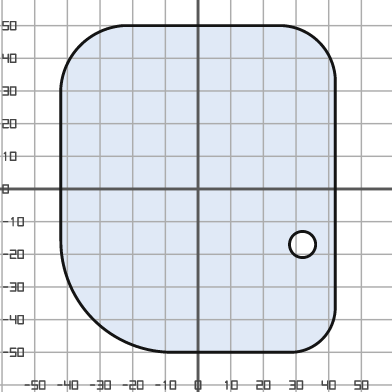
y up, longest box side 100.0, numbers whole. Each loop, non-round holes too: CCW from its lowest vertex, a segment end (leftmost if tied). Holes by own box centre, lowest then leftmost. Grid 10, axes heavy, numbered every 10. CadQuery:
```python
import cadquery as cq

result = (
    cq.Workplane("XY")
    .moveTo(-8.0, -50.0)
    .lineTo(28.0, -50.0)
    .threePointArc((38.0, -46.0), (42.0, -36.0))
    .lineTo(42.0, 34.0)
    .threePointArc((37.0, 45.0), (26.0, 50.0))
    .lineTo(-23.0, 50.0)
    .threePointArc((-36.0, 44.0), (-42.0, 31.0))
    .lineTo(-42.0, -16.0)
    .threePointArc((-32.0, -40.0), (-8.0, -50.0))
    .close()
    .moveTo(32.0, -17.0)
    .circle(4.0)
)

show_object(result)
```